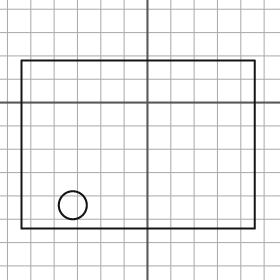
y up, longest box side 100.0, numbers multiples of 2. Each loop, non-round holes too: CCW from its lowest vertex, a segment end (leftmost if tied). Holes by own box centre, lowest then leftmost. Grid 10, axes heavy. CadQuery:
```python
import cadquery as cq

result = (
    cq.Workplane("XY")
    .moveTo(-54.0, -54.0)
    .lineTo(46.0, -54.0)
    .lineTo(46.0, 18.0)
    .lineTo(-54.0, 18.0)
    .close()
    .moveTo(-32.0, -44.0)
    .circle(6.0)
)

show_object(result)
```